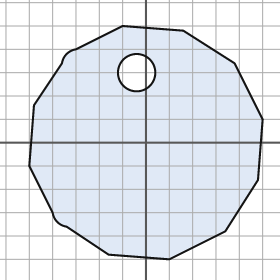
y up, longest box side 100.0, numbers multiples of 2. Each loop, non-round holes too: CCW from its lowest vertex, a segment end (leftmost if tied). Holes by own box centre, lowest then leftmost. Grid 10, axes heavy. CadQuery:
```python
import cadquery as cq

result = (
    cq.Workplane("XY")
    .moveTo(10.0, -50.0)
    .lineTo(34.0, -38.0)
    .lineTo(48.0, -16.0)
    .lineTo(50.0, 10.0)
    .lineTo(38.0, 34.0)
    .lineTo(16.0, 48.0)
    .lineTo(-10.0, 50.0)
    .lineTo(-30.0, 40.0)
    .threePointArc((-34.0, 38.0), (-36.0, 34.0))
    .lineTo(-48.0, 16.0)
    .lineTo(-50.0, -10.0)
    .lineTo(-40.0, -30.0)
    .threePointArc((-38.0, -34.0), (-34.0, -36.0))
    .lineTo(-16.0, -48.0)
    .close()
    .moveTo(-4.0, 30.0)
    .circle(8.0)
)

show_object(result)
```